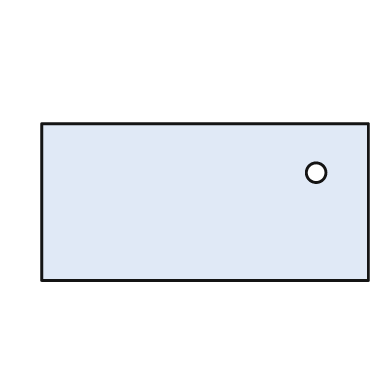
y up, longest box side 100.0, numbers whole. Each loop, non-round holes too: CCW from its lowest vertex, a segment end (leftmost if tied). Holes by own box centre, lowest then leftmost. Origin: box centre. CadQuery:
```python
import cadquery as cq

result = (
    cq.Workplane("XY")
    .moveTo(-50.0, -24.0)
    .lineTo(50.0, -24.0)
    .lineTo(50.0, 24.0)
    .lineTo(-50.0, 24.0)
    .close()
    .moveTo(34.0, 9.0)
    .circle(3.0)
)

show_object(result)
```